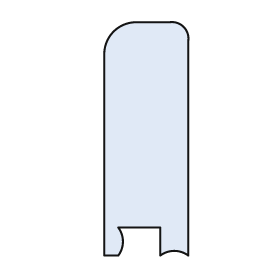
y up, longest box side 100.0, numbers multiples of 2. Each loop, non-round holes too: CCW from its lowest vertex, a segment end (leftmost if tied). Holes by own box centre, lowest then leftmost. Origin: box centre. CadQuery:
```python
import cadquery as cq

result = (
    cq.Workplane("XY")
    .moveTo(-18.0, -50.0)
    .lineTo(-12.0, -50.0)
    .threePointArc((-10.0, -44.0), (-12.0, -38.0))
    .lineTo(6.0, -38.0)
    .lineTo(6.0, -50.0)
    .threePointArc((12.0, -48.0), (18.0, -50.0))
    .lineTo(18.0, 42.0)
    .threePointArc((16.0, 48.0), (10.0, 50.0))
    .lineTo(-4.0, 50.0)
    .threePointArc((-14.0, 46.0), (-18.0, 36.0))
    .close()
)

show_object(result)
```